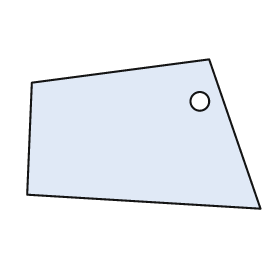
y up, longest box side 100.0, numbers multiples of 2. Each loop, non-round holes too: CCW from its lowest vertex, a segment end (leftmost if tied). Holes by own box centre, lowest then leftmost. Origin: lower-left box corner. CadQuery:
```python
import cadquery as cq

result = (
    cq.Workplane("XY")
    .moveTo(100.0, 0.0)
    .lineTo(78.0, 64.0)
    .lineTo(2.0, 54.0)
    .lineTo(0.0, 6.0)
    .close()
    .moveTo(74.0, 46.0)
    .circle(4.0)
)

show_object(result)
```